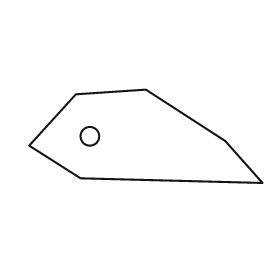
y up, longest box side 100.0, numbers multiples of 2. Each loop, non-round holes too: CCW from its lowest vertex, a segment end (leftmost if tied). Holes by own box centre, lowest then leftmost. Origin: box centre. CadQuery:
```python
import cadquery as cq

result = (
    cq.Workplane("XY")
    .moveTo(50.0, -20.0)
    .lineTo(34.0, -2.0)
    .lineTo(0.0, 20.0)
    .lineTo(-30.0, 18.0)
    .lineTo(-50.0, -4.0)
    .lineTo(-28.0, -18.0)
    .close()
    .moveTo(-24.0, 0.0)
    .circle(4.0)
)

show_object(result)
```